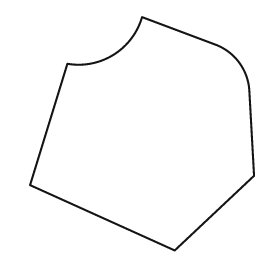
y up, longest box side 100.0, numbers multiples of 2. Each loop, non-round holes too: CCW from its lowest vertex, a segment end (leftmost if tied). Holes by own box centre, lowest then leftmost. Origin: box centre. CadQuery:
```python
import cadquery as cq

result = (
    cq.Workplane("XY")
    .moveTo(14.0, -50.0)
    .lineTo(48.0, -18.0)
    .lineTo(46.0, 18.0)
    .threePointArc((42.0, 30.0), (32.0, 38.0))
    .lineTo(0.0, 50.0)
    .threePointArc((-12.0, 34.0), (-32.0, 30.0))
    .lineTo(-48.0, -22.0)
    .close()
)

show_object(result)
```